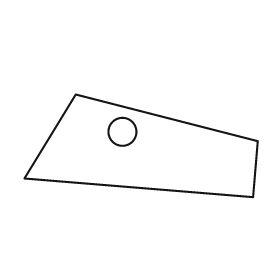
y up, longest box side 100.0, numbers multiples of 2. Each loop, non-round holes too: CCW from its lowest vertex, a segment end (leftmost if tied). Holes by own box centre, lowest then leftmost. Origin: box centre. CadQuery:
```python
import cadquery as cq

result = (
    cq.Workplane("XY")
    .moveTo(48.0, -22.0)
    .lineTo(50.0, 2.0)
    .lineTo(-28.0, 22.0)
    .lineTo(-50.0, -14.0)
    .close()
    .moveTo(-8.0, 6.0)
    .circle(6.0)
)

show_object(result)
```